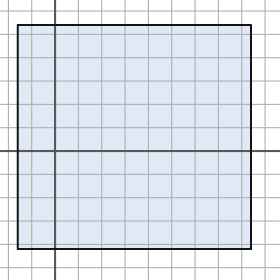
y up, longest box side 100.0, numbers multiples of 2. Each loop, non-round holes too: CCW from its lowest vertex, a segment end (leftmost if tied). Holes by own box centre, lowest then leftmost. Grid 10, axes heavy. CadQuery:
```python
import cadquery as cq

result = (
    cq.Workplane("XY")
    .moveTo(-16.0, -42.0)
    .lineTo(84.0, -42.0)
    .lineTo(84.0, 54.0)
    .lineTo(-16.0, 54.0)
    .close()
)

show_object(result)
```